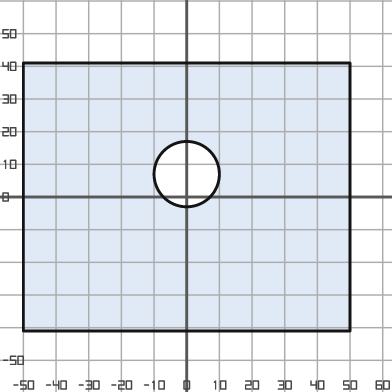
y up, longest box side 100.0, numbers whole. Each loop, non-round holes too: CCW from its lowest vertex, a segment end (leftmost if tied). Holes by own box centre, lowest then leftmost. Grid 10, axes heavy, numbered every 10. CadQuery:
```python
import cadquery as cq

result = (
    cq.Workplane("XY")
    .moveTo(-50.0, -41.0)
    .lineTo(50.0, -41.0)
    .lineTo(50.0, 41.0)
    .lineTo(-50.0, 41.0)
    .close()
    .moveTo(0.0, 7.0)
    .circle(10.0)
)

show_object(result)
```